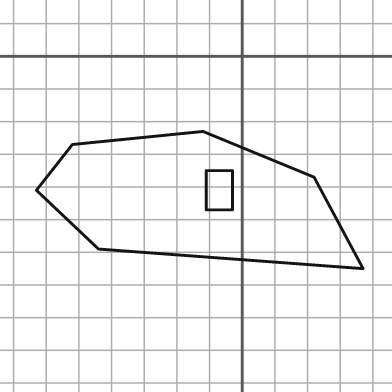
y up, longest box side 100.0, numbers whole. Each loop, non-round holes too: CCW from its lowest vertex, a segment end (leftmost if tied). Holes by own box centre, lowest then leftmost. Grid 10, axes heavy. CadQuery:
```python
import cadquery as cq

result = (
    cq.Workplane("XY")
    .moveTo(37.0, -65.0)
    .lineTo(22.0, -37.0)
    .lineTo(-12.0, -23.0)
    .lineTo(-52.0, -27.0)
    .lineTo(-63.0, -41.0)
    .lineTo(-44.0, -59.0)
    .close()
    .moveTo(-11.0, -47.0)
    .lineTo(-3.0, -47.0)
    .lineTo(-3.0, -35.0)
    .lineTo(-11.0, -35.0)
    .close()
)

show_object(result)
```